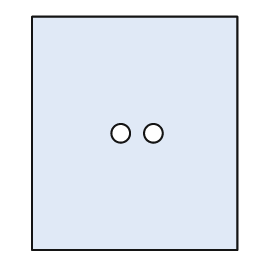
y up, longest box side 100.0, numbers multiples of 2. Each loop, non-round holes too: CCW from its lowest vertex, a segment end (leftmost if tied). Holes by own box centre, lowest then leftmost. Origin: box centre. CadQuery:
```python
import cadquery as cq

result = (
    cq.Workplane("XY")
    .moveTo(-44.0, -50.0)
    .lineTo(44.0, -50.0)
    .lineTo(44.0, 50.0)
    .lineTo(-44.0, 50.0)
    .close()
    .moveTo(-6.0, 0.0)
    .circle(4.0)
    .moveTo(8.0, 0.0)
    .circle(4.0)
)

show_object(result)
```